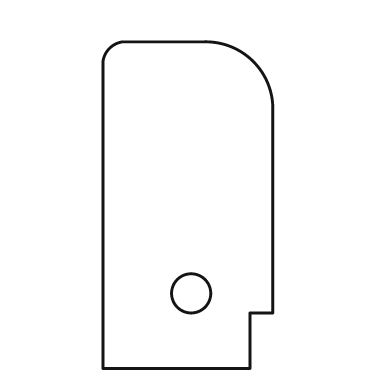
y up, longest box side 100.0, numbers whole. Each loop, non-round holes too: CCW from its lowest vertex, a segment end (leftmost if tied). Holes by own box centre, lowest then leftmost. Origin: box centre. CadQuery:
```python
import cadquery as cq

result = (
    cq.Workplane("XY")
    .moveTo(-26.0, -50.0)
    .lineTo(19.0, -50.0)
    .lineTo(19.0, -33.0)
    .lineTo(26.0, -33.0)
    .lineTo(26.0, 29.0)
    .threePointArc((20.0, 44.0), (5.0, 50.0))
    .lineTo(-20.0, 50.0)
    .threePointArc((-24.0, 48.0), (-26.0, 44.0))
    .close()
    .moveTo(1.0, -27.0)
    .circle(6.0)
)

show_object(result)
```